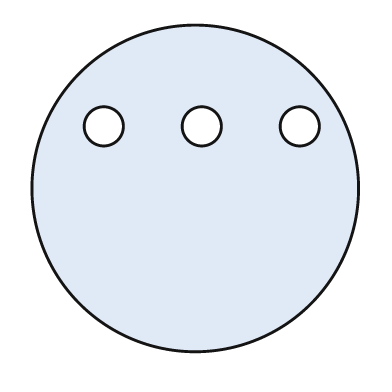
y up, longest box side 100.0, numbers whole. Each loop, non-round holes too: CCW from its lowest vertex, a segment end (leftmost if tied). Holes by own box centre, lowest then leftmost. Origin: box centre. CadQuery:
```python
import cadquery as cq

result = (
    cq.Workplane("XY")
    .moveTo(0.0, 0.0)
    .circle(50.0)
    .moveTo(-28.0, 19.0)
    .circle(6.0)
    .moveTo(2.0, 19.0)
    .circle(6.0)
    .moveTo(32.0, 19.0)
    .circle(6.0)
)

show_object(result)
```